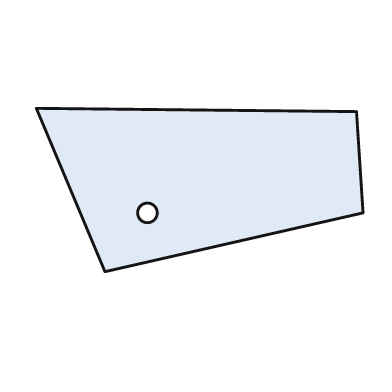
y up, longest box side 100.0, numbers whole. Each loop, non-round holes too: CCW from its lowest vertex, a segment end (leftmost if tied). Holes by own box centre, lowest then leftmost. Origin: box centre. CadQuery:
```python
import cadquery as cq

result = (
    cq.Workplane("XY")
    .moveTo(-29.0, -25.0)
    .lineTo(50.0, -7.0)
    .lineTo(48.0, 24.0)
    .lineTo(-50.0, 25.0)
    .close()
    .moveTo(-16.0, -7.0)
    .circle(3.0)
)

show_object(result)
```